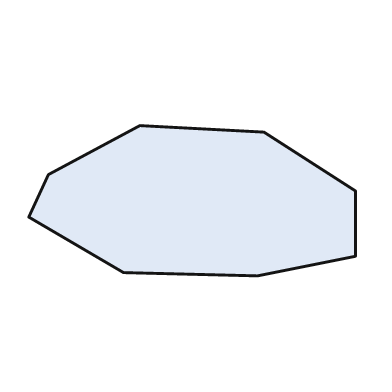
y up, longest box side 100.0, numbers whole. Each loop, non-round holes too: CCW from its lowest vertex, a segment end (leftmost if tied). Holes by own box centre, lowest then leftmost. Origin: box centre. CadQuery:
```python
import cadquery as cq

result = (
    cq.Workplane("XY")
    .moveTo(20.0, -23.0)
    .lineTo(50.0, -17.0)
    .lineTo(50.0, 3.0)
    .lineTo(22.0, 21.0)
    .lineTo(-16.0, 23.0)
    .lineTo(-44.0, 8.0)
    .lineTo(-50.0, -5.0)
    .lineTo(-21.0, -22.0)
    .close()
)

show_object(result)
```